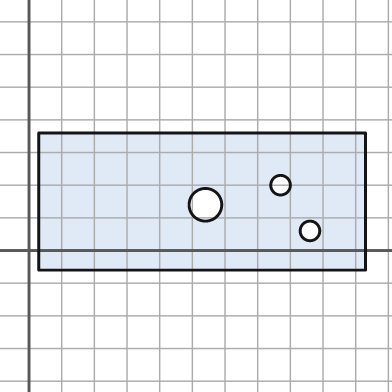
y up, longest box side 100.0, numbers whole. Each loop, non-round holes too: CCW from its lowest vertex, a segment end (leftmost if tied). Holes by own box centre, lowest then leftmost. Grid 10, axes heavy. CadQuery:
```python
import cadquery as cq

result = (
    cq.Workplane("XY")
    .moveTo(3.0, -6.0)
    .lineTo(103.0, -6.0)
    .lineTo(103.0, 36.0)
    .lineTo(3.0, 36.0)
    .close()
    .moveTo(86.0, 6.0)
    .circle(3.0)
    .moveTo(54.0, 14.0)
    .circle(5.0)
    .moveTo(77.0, 20.0)
    .circle(3.0)
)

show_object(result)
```